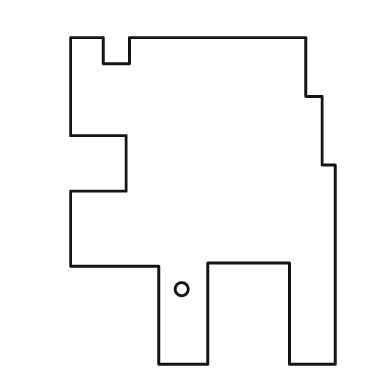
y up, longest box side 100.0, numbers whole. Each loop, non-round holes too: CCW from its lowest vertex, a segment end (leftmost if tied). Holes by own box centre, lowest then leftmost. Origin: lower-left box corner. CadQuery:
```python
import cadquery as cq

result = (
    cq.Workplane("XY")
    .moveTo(27.0, 0.0)
    .lineTo(42.0, 0.0)
    .lineTo(42.0, 31.0)
    .lineTo(67.0, 31.0)
    .lineTo(67.0, 0.0)
    .lineTo(81.0, 0.0)
    .lineTo(81.0, 61.0)
    .lineTo(77.0, 61.0)
    .lineTo(77.0, 82.0)
    .lineTo(72.0, 82.0)
    .lineTo(72.0, 100.0)
    .lineTo(18.0, 100.0)
    .lineTo(18.0, 92.0)
    .lineTo(10.0, 92.0)
    .lineTo(10.0, 100.0)
    .lineTo(0.0, 100.0)
    .lineTo(0.0, 70.0)
    .lineTo(17.0, 70.0)
    .lineTo(17.0, 53.0)
    .lineTo(0.0, 53.0)
    .lineTo(0.0, 30.0)
    .lineTo(27.0, 30.0)
    .close()
    .moveTo(34.0, 23.0)
    .circle(2.0)
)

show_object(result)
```